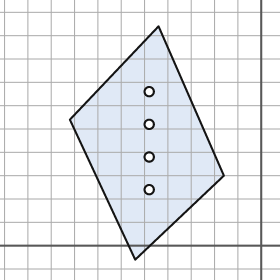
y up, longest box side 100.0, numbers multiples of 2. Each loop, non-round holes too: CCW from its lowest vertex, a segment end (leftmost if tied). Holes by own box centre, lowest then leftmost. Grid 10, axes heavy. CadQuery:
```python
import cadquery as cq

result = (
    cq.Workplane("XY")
    .moveTo(-54.0, -6.0)
    .lineTo(-16.0, 30.0)
    .lineTo(-44.0, 94.0)
    .lineTo(-82.0, 54.0)
    .close()
    .moveTo(-48.0, 24.0)
    .circle(2.0)
    .moveTo(-48.0, 38.0)
    .circle(2.0)
    .moveTo(-48.0, 52.0)
    .circle(2.0)
    .moveTo(-48.0, 66.0)
    .circle(2.0)
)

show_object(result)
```